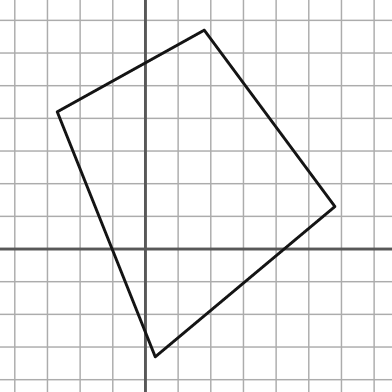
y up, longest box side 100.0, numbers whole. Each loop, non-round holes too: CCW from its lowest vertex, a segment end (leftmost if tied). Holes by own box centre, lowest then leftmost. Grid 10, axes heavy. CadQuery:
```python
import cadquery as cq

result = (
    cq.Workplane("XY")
    .moveTo(3.0, -33.0)
    .lineTo(58.0, 13.0)
    .lineTo(18.0, 67.0)
    .lineTo(-27.0, 42.0)
    .close()
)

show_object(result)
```